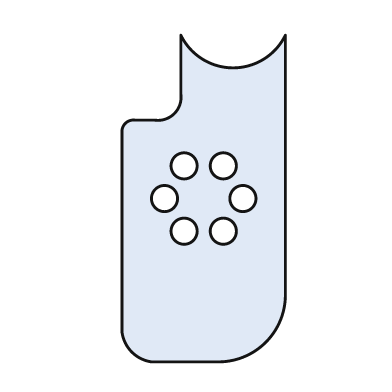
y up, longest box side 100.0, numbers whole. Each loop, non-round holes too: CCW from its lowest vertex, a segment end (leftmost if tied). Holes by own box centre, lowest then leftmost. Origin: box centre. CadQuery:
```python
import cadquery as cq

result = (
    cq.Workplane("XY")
    .moveTo(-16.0, -50.0)
    .lineTo(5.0, -50.0)
    .threePointArc((19.0, -44.0), (25.0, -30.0))
    .lineTo(25.0, 50.0)
    .threePointArc((9.0, 40.0), (-7.0, 50.0))
    .lineTo(-7.0, 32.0)
    .threePointArc((-9.0, 26.0), (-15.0, 24.0))
    .lineTo(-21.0, 24.0)
    .threePointArc((-24.0, 23.0), (-25.0, 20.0))
    .lineTo(-25.0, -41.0)
    .threePointArc((-22.0, -47.0), (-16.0, -50.0))
    .close()
    .moveTo(-6.0, -10.0)
    .circle(4.0)
    .moveTo(6.0, -10.0)
    .circle(4.0)
    .moveTo(-12.0, 0.0)
    .circle(4.0)
    .moveTo(12.0, 0.0)
    .circle(4.0)
    .moveTo(-6.0, 10.0)
    .circle(4.0)
    .moveTo(6.0, 10.0)
    .circle(4.0)
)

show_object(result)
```